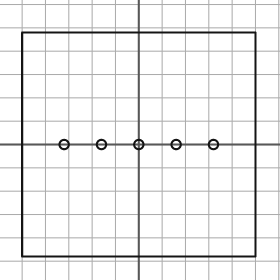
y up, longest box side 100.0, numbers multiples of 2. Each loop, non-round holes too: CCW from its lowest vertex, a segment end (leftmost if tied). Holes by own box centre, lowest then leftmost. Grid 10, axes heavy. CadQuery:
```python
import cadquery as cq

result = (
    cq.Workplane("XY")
    .moveTo(-50.0, -48.0)
    .lineTo(50.0, -48.0)
    .lineTo(50.0, 48.0)
    .lineTo(-50.0, 48.0)
    .close()
    .moveTo(-32.0, 0.0)
    .circle(2.0)
    .moveTo(-16.0, 0.0)
    .circle(2.0)
    .moveTo(0.0, 0.0)
    .circle(2.0)
    .moveTo(16.0, 0.0)
    .circle(2.0)
    .moveTo(32.0, 0.0)
    .circle(2.0)
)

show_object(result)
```